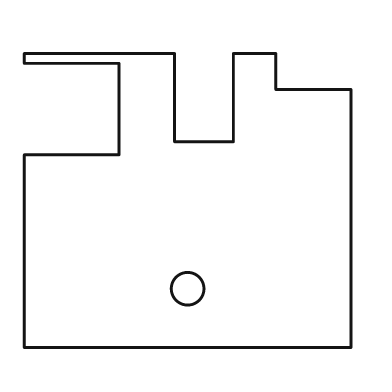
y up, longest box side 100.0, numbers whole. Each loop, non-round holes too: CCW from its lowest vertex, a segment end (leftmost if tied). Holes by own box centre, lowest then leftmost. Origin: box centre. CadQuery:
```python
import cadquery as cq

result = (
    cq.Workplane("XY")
    .moveTo(-50.0, -45.0)
    .lineTo(50.0, -45.0)
    .lineTo(50.0, 34.0)
    .lineTo(27.0, 34.0)
    .lineTo(27.0, 45.0)
    .lineTo(14.0, 45.0)
    .lineTo(14.0, 18.0)
    .lineTo(-4.0, 18.0)
    .lineTo(-4.0, 45.0)
    .lineTo(-50.0, 45.0)
    .lineTo(-50.0, 42.0)
    .lineTo(-21.0, 42.0)
    .lineTo(-21.0, 14.0)
    .lineTo(-50.0, 14.0)
    .close()
    .moveTo(0.0, -27.0)
    .circle(5.0)
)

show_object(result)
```